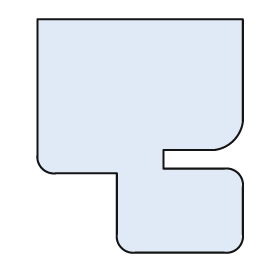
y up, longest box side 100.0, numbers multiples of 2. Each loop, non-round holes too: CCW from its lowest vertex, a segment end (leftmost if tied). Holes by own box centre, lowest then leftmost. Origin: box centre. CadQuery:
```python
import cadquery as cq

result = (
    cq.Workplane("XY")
    .moveTo(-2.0, -50.0)
    .lineTo(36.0, -50.0)
    .threePointArc((42.0, -48.0), (44.0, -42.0))
    .lineTo(44.0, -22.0)
    .threePointArc((42.0, -16.0), (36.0, -14.0))
    .lineTo(10.0, -14.0)
    .lineTo(10.0, -6.0)
    .lineTo(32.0, -6.0)
    .threePointArc((40.0, -2.0), (44.0, 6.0))
    .lineTo(44.0, 50.0)
    .lineTo(-44.0, 50.0)
    .lineTo(-44.0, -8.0)
    .threePointArc((-42.0, -14.0), (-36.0, -16.0))
    .lineTo(-10.0, -16.0)
    .lineTo(-10.0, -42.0)
    .threePointArc((-8.0, -48.0), (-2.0, -50.0))
    .close()
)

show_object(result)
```